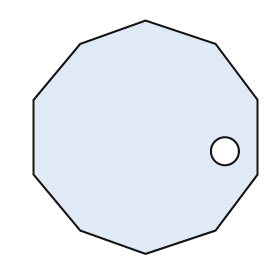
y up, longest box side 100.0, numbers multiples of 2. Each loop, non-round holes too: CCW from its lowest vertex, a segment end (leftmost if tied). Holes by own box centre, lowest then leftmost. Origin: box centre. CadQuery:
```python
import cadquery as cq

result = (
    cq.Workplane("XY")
    .moveTo(0.0, -50.0)
    .lineTo(30.0, -40.0)
    .lineTo(48.0, -16.0)
    .lineTo(48.0, 16.0)
    .lineTo(30.0, 40.0)
    .lineTo(0.0, 50.0)
    .lineTo(-28.0, 40.0)
    .lineTo(-48.0, 16.0)
    .lineTo(-48.0, -16.0)
    .lineTo(-28.0, -40.0)
    .close()
    .moveTo(34.0, -6.0)
    .circle(6.0)
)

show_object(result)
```